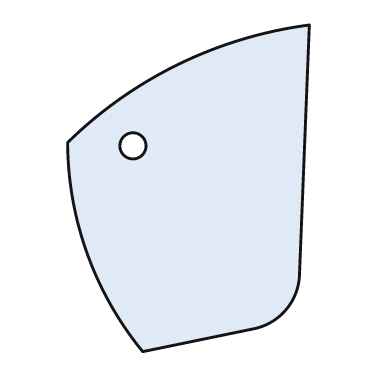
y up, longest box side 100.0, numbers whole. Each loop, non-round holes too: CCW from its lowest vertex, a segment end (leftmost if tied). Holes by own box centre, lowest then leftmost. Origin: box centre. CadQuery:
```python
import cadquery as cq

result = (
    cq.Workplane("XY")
    .moveTo(-14.0, -50.0)
    .lineTo(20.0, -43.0)
    .threePointArc((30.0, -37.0), (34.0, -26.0))
    .lineTo(37.0, 50.0)
    .threePointArc((-3.0, 38.0), (-37.0, 14.0))
    .threePointArc((-31.0, -20.0), (-14.0, -50.0))
    .close()
    .moveTo(-17.0, 13.0)
    .circle(4.0)
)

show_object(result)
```